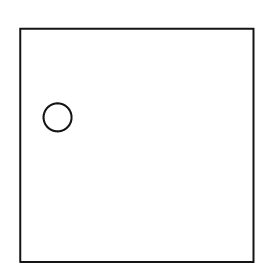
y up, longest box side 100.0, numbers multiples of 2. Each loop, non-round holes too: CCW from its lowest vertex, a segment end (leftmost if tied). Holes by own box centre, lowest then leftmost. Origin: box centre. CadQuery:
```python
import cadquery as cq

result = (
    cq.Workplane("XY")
    .moveTo(-50.0, -50.0)
    .lineTo(50.0, -50.0)
    .lineTo(50.0, 50.0)
    .lineTo(-50.0, 50.0)
    .close()
    .moveTo(-34.0, 12.0)
    .circle(6.0)
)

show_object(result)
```